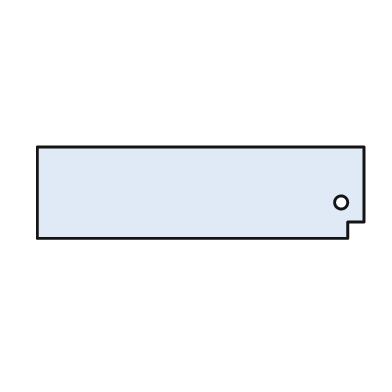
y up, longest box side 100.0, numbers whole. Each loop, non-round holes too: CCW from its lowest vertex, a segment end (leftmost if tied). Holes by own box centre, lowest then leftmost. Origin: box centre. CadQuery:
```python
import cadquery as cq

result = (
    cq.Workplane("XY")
    .moveTo(-50.0, -14.0)
    .lineTo(45.0, -14.0)
    .lineTo(45.0, -9.0)
    .lineTo(50.0, -9.0)
    .lineTo(50.0, 14.0)
    .lineTo(-50.0, 14.0)
    .close()
    .moveTo(43.0, -3.0)
    .circle(2.0)
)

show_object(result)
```